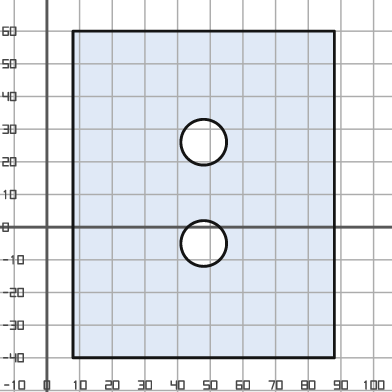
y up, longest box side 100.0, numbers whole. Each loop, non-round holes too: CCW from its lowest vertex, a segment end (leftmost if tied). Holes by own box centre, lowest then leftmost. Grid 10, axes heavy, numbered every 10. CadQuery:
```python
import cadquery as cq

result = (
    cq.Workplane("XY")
    .moveTo(8.0, -40.0)
    .lineTo(88.0, -40.0)
    .lineTo(88.0, 60.0)
    .lineTo(8.0, 60.0)
    .close()
    .moveTo(48.0, -5.0)
    .circle(7.0)
    .moveTo(48.0, 26.0)
    .circle(7.0)
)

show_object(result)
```